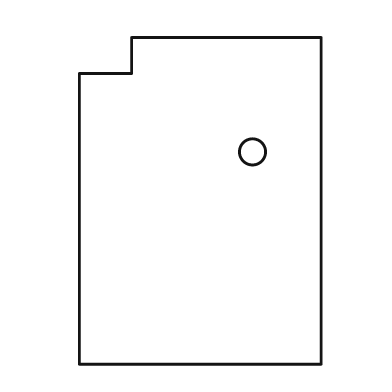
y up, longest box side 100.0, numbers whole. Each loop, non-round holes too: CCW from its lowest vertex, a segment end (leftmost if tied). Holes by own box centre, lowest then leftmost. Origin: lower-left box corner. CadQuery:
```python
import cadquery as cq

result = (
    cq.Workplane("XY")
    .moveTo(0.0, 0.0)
    .lineTo(74.0, 0.0)
    .lineTo(74.0, 100.0)
    .lineTo(16.0, 100.0)
    .lineTo(16.0, 89.0)
    .lineTo(0.0, 89.0)
    .close()
    .moveTo(53.0, 65.0)
    .circle(4.0)
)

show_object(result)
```